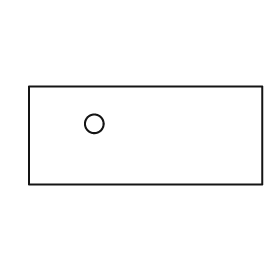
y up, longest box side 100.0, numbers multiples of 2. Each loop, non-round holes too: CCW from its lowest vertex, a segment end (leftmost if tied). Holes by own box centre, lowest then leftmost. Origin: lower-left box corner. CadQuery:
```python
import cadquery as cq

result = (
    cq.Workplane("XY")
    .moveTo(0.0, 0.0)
    .lineTo(100.0, 0.0)
    .lineTo(100.0, 42.0)
    .lineTo(0.0, 42.0)
    .close()
    .moveTo(28.0, 26.0)
    .circle(4.0)
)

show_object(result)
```